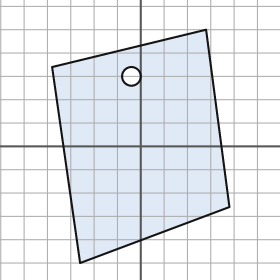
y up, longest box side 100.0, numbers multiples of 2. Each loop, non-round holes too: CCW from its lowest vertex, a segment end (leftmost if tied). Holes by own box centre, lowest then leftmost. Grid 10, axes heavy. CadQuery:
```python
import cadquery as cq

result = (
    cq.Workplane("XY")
    .moveTo(-26.0, -50.0)
    .lineTo(38.0, -26.0)
    .lineTo(28.0, 50.0)
    .lineTo(-38.0, 34.0)
    .close()
    .moveTo(-4.0, 30.0)
    .circle(4.0)
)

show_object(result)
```